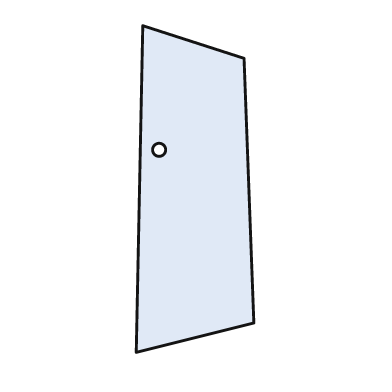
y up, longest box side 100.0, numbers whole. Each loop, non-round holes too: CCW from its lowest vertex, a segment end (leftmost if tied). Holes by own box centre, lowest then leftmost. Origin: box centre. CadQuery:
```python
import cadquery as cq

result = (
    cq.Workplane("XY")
    .moveTo(-18.0, -50.0)
    .lineTo(18.0, -41.0)
    .lineTo(15.0, 40.0)
    .lineTo(-16.0, 50.0)
    .close()
    .moveTo(-11.0, 12.0)
    .circle(2.0)
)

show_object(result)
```